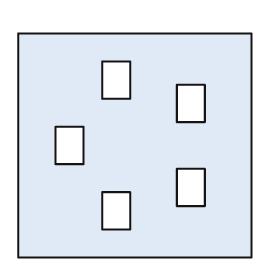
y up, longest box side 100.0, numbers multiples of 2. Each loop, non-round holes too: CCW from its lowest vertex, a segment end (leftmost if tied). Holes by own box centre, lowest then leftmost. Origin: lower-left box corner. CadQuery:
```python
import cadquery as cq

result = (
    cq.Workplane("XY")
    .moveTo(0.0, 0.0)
    .lineTo(100.0, 0.0)
    .lineTo(100.0, 96.0)
    .lineTo(0.0, 96.0)
    .close()
    .moveTo(36.0, 12.0)
    .lineTo(48.0, 12.0)
    .lineTo(48.0, 28.0)
    .lineTo(36.0, 28.0)
    .close()
    .moveTo(68.0, 22.0)
    .lineTo(80.0, 22.0)
    .lineTo(80.0, 38.0)
    .lineTo(68.0, 38.0)
    .close()
    .moveTo(16.0, 40.0)
    .lineTo(28.0, 40.0)
    .lineTo(28.0, 56.0)
    .lineTo(16.0, 56.0)
    .close()
    .moveTo(68.0, 58.0)
    .lineTo(80.0, 58.0)
    .lineTo(80.0, 74.0)
    .lineTo(68.0, 74.0)
    .close()
    .moveTo(36.0, 68.0)
    .lineTo(48.0, 68.0)
    .lineTo(48.0, 84.0)
    .lineTo(36.0, 84.0)
    .close()
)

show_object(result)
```